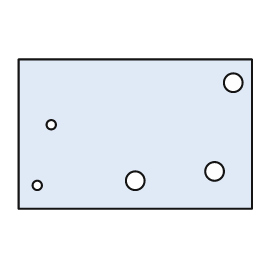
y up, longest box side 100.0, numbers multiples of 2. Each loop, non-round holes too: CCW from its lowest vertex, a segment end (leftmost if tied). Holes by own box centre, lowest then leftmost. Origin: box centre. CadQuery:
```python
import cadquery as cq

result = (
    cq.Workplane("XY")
    .moveTo(-50.0, -32.0)
    .lineTo(50.0, -32.0)
    .lineTo(50.0, 32.0)
    .lineTo(-50.0, 32.0)
    .close()
    .moveTo(-42.0, -22.0)
    .circle(2.0)
    .moveTo(0.0, -20.0)
    .circle(4.0)
    .moveTo(34.0, -16.0)
    .circle(4.0)
    .moveTo(-36.0, 4.0)
    .circle(2.0)
    .moveTo(42.0, 22.0)
    .circle(4.0)
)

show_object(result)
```